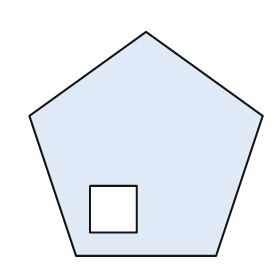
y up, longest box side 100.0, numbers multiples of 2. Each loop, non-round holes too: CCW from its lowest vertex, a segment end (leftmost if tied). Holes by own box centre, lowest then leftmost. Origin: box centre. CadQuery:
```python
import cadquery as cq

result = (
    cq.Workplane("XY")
    .moveTo(-30.0, -48.0)
    .lineTo(30.0, -48.0)
    .lineTo(50.0, 12.0)
    .lineTo(0.0, 48.0)
    .lineTo(-50.0, 12.0)
    .close()
    .moveTo(-24.0, -38.0)
    .lineTo(-4.0, -38.0)
    .lineTo(-4.0, -18.0)
    .lineTo(-24.0, -18.0)
    .close()
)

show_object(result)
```